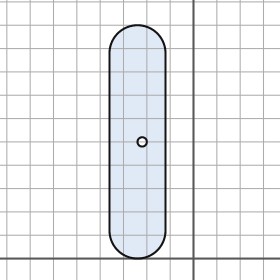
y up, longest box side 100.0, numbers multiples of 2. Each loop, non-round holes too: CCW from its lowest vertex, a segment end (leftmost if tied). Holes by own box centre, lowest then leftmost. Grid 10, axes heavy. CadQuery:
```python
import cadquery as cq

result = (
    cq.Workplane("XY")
    .moveTo(-36.0, 12.0)
    .threePointArc((-24.0, 0.0), (-12.0, 12.0))
    .lineTo(-12.0, 88.0)
    .threePointArc((-24.0, 100.0), (-36.0, 88.0))
    .close()
    .moveTo(-22.0, 50.0)
    .circle(2.0)
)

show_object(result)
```